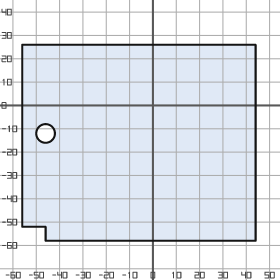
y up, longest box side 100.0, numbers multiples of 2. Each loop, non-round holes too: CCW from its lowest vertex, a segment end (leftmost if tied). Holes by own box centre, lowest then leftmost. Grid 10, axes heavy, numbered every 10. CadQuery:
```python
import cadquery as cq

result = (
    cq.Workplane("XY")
    .moveTo(-46.0, -58.0)
    .lineTo(44.0, -58.0)
    .lineTo(44.0, 26.0)
    .lineTo(-56.0, 26.0)
    .lineTo(-56.0, -52.0)
    .lineTo(-46.0, -52.0)
    .close()
    .moveTo(-46.0, -12.0)
    .circle(4.0)
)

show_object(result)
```